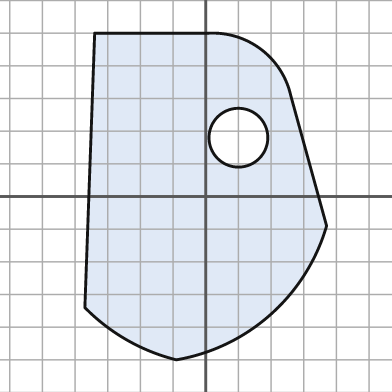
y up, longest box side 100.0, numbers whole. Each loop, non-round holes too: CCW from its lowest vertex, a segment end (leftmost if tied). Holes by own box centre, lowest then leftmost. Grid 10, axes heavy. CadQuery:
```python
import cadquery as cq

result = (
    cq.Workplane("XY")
    .moveTo(-9.0, -50.0)
    .threePointArc((20.0, -36.0), (37.0, -9.0))
    .lineTo(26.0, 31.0)
    .threePointArc((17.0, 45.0), (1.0, 50.0))
    .lineTo(-34.0, 50.0)
    .lineTo(-37.0, -34.0)
    .threePointArc((-24.0, -44.0), (-9.0, -50.0))
    .close()
    .moveTo(10.0, 18.0)
    .circle(9.0)
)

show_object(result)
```